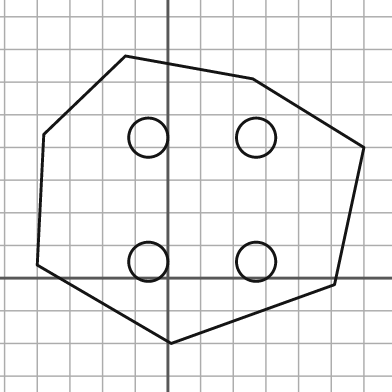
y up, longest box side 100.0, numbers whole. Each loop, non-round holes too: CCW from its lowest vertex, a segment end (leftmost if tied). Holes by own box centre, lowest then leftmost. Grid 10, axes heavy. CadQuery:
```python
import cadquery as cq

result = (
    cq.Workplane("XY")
    .moveTo(1.0, -20.0)
    .lineTo(51.0, -2.0)
    .lineTo(60.0, 40.0)
    .lineTo(26.0, 61.0)
    .lineTo(-13.0, 68.0)
    .lineTo(-38.0, 44.0)
    .lineTo(-40.0, 4.0)
    .close()
    .moveTo(-6.0, 5.0)
    .circle(6.0)
    .moveTo(27.0, 5.0)
    .circle(6.0)
    .moveTo(-6.0, 43.0)
    .circle(6.0)
    .moveTo(27.0, 43.0)
    .circle(6.0)
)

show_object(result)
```